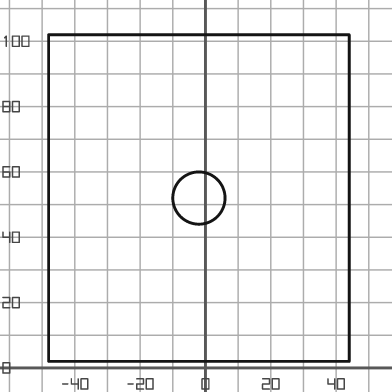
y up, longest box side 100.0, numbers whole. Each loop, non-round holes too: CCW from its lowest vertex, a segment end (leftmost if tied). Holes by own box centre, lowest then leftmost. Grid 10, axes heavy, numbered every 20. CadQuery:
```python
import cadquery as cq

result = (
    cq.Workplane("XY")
    .moveTo(-48.0, 2.0)
    .lineTo(44.0, 2.0)
    .lineTo(44.0, 102.0)
    .lineTo(-48.0, 102.0)
    .close()
    .moveTo(-2.0, 52.0)
    .circle(8.0)
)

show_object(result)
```